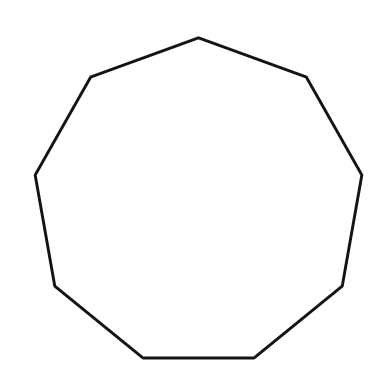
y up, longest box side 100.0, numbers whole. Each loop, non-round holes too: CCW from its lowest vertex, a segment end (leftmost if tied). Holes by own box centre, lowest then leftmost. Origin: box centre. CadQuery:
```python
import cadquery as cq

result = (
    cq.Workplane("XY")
    .moveTo(-17.0, -49.0)
    .lineTo(17.0, -49.0)
    .lineTo(44.0, -27.0)
    .lineTo(50.0, 7.0)
    .lineTo(33.0, 37.0)
    .lineTo(0.0, 49.0)
    .lineTo(-33.0, 37.0)
    .lineTo(-50.0, 7.0)
    .lineTo(-44.0, -27.0)
    .close()
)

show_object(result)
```